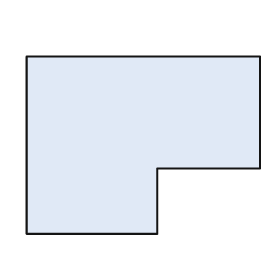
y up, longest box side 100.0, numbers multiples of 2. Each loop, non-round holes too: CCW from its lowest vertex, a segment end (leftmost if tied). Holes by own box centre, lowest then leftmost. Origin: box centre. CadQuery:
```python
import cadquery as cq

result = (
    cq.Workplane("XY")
    .moveTo(-50.0, -38.0)
    .lineTo(6.0, -38.0)
    .lineTo(6.0, -10.0)
    .lineTo(50.0, -10.0)
    .lineTo(50.0, 38.0)
    .lineTo(-50.0, 38.0)
    .close()
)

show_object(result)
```